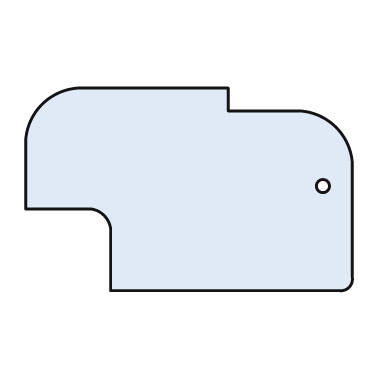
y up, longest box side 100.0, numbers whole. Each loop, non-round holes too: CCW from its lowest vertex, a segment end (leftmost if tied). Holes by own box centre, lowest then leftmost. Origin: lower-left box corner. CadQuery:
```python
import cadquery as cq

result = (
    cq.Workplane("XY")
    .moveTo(26.0, 0.0)
    .lineTo(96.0, 0.0)
    .threePointArc((99.0, 1.0), (100.0, 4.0))
    .lineTo(100.0, 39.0)
    .threePointArc((95.0, 50.0), (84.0, 55.0))
    .lineTo(62.0, 55.0)
    .lineTo(62.0, 62.0)
    .lineTo(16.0, 62.0)
    .threePointArc((5.0, 57.0), (0.0, 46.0))
    .lineTo(0.0, 25.0)
    .lineTo(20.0, 25.0)
    .threePointArc((24.0, 23.0), (26.0, 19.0))
    .close()
    .moveTo(91.0, 32.0)
    .circle(2.0)
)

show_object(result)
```